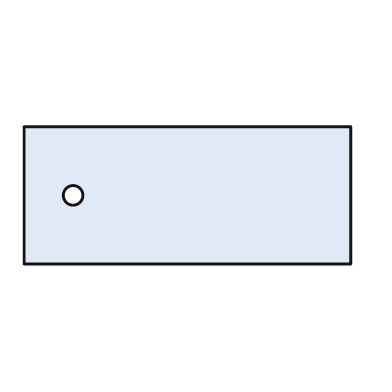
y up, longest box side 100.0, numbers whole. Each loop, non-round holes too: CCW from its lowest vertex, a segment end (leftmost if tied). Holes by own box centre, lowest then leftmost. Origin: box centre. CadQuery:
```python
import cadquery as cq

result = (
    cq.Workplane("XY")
    .moveTo(-50.0, -21.0)
    .lineTo(50.0, -21.0)
    .lineTo(50.0, 21.0)
    .lineTo(-50.0, 21.0)
    .close()
    .moveTo(-35.0, 0.0)
    .circle(3.0)
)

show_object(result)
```